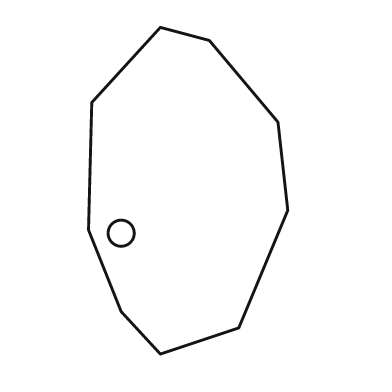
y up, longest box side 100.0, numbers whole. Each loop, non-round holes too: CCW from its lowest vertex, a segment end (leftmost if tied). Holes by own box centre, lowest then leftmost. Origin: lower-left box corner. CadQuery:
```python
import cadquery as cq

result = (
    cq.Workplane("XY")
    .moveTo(22.0, 0.0)
    .lineTo(46.0, 8.0)
    .lineTo(61.0, 44.0)
    .lineTo(58.0, 71.0)
    .lineTo(37.0, 96.0)
    .lineTo(22.0, 100.0)
    .lineTo(1.0, 77.0)
    .lineTo(0.0, 38.0)
    .lineTo(10.0, 13.0)
    .close()
    .moveTo(10.0, 37.0)
    .circle(4.0)
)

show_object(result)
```